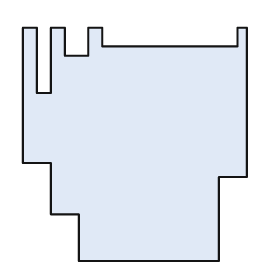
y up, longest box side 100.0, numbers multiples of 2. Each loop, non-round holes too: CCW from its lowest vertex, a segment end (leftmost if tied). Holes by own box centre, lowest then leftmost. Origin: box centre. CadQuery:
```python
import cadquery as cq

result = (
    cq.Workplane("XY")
    .moveTo(-24.0, -50.0)
    .lineTo(36.0, -50.0)
    .lineTo(36.0, -14.0)
    .lineTo(48.0, -14.0)
    .lineTo(48.0, 50.0)
    .lineTo(44.0, 50.0)
    .lineTo(44.0, 42.0)
    .lineTo(-14.0, 42.0)
    .lineTo(-14.0, 50.0)
    .lineTo(-20.0, 50.0)
    .lineTo(-20.0, 38.0)
    .lineTo(-30.0, 38.0)
    .lineTo(-30.0, 50.0)
    .lineTo(-36.0, 50.0)
    .lineTo(-36.0, 22.0)
    .lineTo(-42.0, 22.0)
    .lineTo(-42.0, 50.0)
    .lineTo(-48.0, 50.0)
    .lineTo(-48.0, -8.0)
    .lineTo(-36.0, -8.0)
    .lineTo(-36.0, -30.0)
    .lineTo(-24.0, -30.0)
    .close()
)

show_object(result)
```